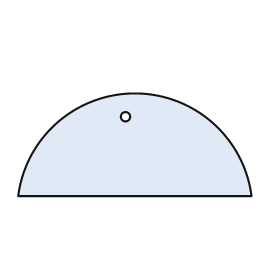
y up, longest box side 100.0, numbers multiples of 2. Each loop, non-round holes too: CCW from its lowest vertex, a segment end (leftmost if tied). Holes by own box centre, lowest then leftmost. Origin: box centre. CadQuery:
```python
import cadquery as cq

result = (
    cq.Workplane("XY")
    .moveTo(-50.0, -22.0)
    .lineTo(50.0, -22.0)
    .threePointArc((0.0, 22.0), (-50.0, -22.0))
    .close()
    .moveTo(-4.0, 12.0)
    .circle(2.0)
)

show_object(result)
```